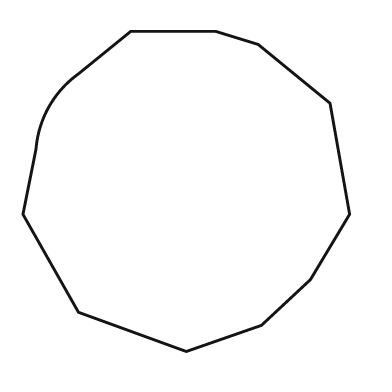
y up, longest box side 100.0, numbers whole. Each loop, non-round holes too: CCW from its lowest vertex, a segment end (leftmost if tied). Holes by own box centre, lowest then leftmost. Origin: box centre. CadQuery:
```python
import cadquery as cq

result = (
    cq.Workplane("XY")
    .moveTo(0.0, -49.0)
    .lineTo(23.0, -41.0)
    .lineTo(38.0, -27.0)
    .lineTo(50.0, -7.0)
    .lineTo(44.0, 27.0)
    .lineTo(22.0, 45.0)
    .lineTo(9.0, 49.0)
    .lineTo(-17.0, 49.0)
    .lineTo(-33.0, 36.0)
    .threePointArc((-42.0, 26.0), (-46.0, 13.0))
    .lineTo(-50.0, -7.0)
    .lineTo(-33.0, -37.0)
    .close()
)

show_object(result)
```